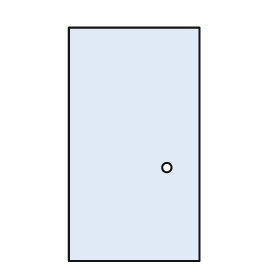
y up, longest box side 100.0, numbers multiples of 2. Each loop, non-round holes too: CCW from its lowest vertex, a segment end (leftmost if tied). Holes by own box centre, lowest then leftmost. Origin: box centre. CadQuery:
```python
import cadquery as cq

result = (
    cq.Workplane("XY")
    .moveTo(-28.0, -50.0)
    .lineTo(28.0, -50.0)
    .lineTo(28.0, 50.0)
    .lineTo(-28.0, 50.0)
    .close()
    .moveTo(14.0, -10.0)
    .circle(2.0)
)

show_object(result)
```